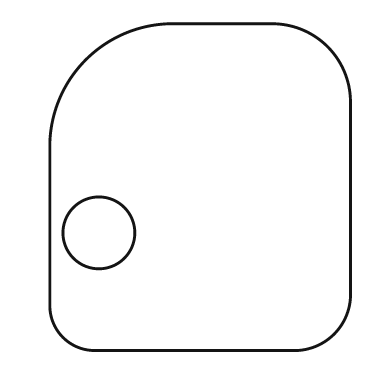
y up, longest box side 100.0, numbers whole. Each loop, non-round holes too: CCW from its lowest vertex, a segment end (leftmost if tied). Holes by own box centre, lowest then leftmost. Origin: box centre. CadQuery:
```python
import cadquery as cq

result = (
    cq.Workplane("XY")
    .moveTo(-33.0, -50.0)
    .lineTo(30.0, -50.0)
    .threePointArc((41.0, -45.0), (46.0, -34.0))
    .lineTo(46.0, 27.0)
    .threePointArc((39.0, 43.0), (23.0, 50.0))
    .lineTo(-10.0, 50.0)
    .threePointArc((-35.0, 39.0), (-46.0, 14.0))
    .lineTo(-46.0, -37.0)
    .threePointArc((-42.0, -46.0), (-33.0, -50.0))
    .close()
    .moveTo(-31.0, -14.0)
    .circle(11.0)
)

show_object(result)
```